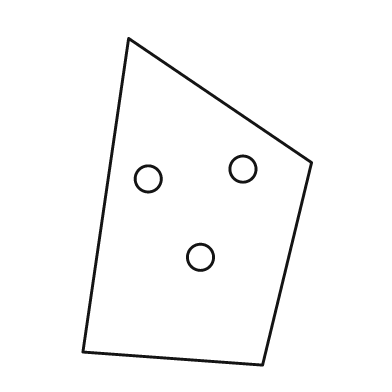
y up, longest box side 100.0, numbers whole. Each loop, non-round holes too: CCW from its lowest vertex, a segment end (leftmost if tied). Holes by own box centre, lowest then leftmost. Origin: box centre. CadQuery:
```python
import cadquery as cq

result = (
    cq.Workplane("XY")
    .moveTo(20.0, -50.0)
    .lineTo(35.0, 12.0)
    .lineTo(-21.0, 50.0)
    .lineTo(-35.0, -46.0)
    .close()
    .moveTo(1.0, -17.0)
    .circle(4.0)
    .moveTo(-15.0, 7.0)
    .circle(4.0)
    .moveTo(14.0, 10.0)
    .circle(4.0)
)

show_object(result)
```